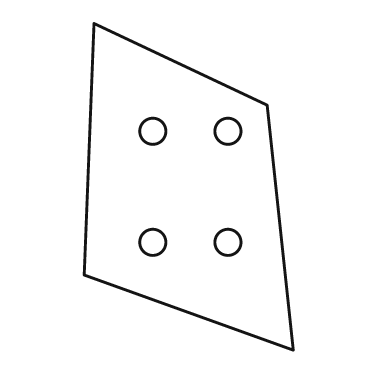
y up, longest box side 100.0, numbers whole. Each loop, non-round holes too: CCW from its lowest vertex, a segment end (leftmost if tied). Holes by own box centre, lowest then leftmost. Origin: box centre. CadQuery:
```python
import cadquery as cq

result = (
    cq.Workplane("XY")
    .moveTo(32.0, -50.0)
    .lineTo(24.0, 25.0)
    .lineTo(-29.0, 50.0)
    .lineTo(-32.0, -27.0)
    .close()
    .moveTo(-11.0, -17.0)
    .circle(4.0)
    .moveTo(12.0, -17.0)
    .circle(4.0)
    .moveTo(-11.0, 17.0)
    .circle(4.0)
    .moveTo(12.0, 17.0)
    .circle(4.0)
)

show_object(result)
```